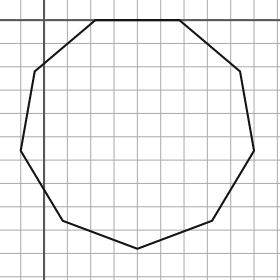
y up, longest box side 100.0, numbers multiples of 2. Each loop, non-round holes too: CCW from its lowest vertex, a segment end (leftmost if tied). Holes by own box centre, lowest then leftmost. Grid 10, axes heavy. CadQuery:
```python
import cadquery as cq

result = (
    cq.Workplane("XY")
    .moveTo(40.0, -98.0)
    .lineTo(72.0, -86.0)
    .lineTo(90.0, -56.0)
    .lineTo(84.0, -22.0)
    .lineTo(58.0, 0.0)
    .lineTo(22.0, 0.0)
    .lineTo(-4.0, -22.0)
    .lineTo(-10.0, -56.0)
    .lineTo(8.0, -86.0)
    .close()
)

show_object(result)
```